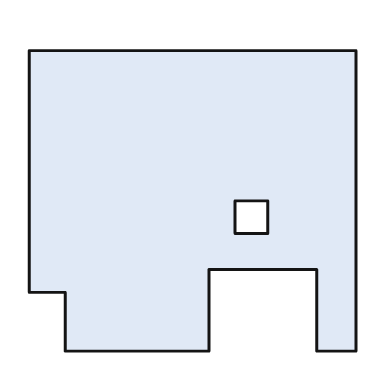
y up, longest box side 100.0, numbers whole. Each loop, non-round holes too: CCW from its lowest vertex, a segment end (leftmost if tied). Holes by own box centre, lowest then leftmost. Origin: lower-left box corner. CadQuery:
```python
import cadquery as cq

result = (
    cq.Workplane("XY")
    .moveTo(11.0, 0.0)
    .lineTo(55.0, 0.0)
    .lineTo(55.0, 25.0)
    .lineTo(88.0, 25.0)
    .lineTo(88.0, 0.0)
    .lineTo(100.0, 0.0)
    .lineTo(100.0, 92.0)
    .lineTo(0.0, 92.0)
    .lineTo(0.0, 18.0)
    .lineTo(11.0, 18.0)
    .close()
    .moveTo(63.0, 36.0)
    .lineTo(73.0, 36.0)
    .lineTo(73.0, 46.0)
    .lineTo(63.0, 46.0)
    .close()
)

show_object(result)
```